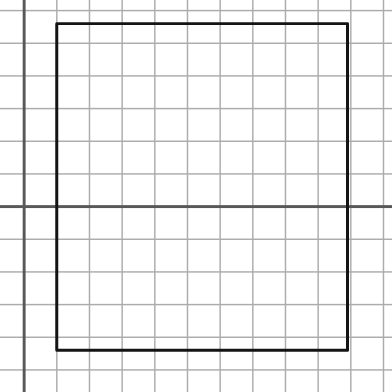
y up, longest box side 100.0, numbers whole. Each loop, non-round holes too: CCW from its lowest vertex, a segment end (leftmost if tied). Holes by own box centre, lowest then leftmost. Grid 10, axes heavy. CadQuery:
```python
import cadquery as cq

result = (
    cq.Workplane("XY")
    .moveTo(10.0, -44.0)
    .lineTo(99.0, -44.0)
    .lineTo(99.0, 56.0)
    .lineTo(10.0, 56.0)
    .close()
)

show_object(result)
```